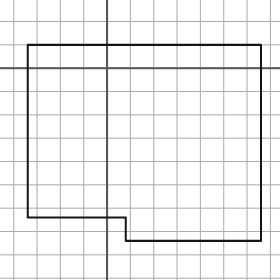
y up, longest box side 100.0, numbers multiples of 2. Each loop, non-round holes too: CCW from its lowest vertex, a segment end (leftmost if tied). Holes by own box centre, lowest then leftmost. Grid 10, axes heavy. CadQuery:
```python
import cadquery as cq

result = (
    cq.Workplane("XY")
    .moveTo(8.0, -74.0)
    .lineTo(66.0, -74.0)
    .lineTo(66.0, 10.0)
    .lineTo(-34.0, 10.0)
    .lineTo(-34.0, -64.0)
    .lineTo(8.0, -64.0)
    .close()
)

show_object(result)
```